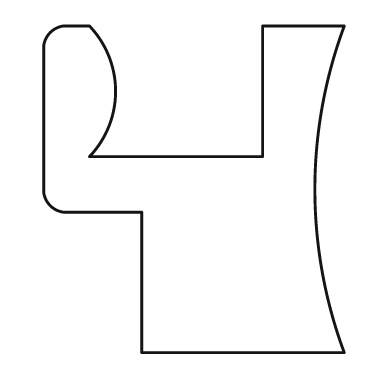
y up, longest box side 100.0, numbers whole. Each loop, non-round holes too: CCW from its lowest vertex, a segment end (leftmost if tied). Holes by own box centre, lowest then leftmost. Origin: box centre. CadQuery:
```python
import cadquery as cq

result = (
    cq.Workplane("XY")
    .moveTo(-16.0, -50.0)
    .lineTo(46.0, -50.0)
    .threePointArc((37.0, 0.0), (46.0, 50.0))
    .lineTo(21.0, 50.0)
    .lineTo(21.0, 10.0)
    .lineTo(-32.0, 10.0)
    .threePointArc((-24.0, 30.0), (-32.0, 50.0))
    .lineTo(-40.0, 50.0)
    .threePointArc((-44.0, 48.0), (-46.0, 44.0))
    .lineTo(-46.0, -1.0)
    .threePointArc((-44.0, -5.0), (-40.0, -7.0))
    .lineTo(-16.0, -7.0)
    .close()
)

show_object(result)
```